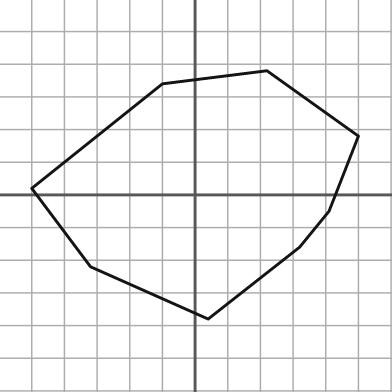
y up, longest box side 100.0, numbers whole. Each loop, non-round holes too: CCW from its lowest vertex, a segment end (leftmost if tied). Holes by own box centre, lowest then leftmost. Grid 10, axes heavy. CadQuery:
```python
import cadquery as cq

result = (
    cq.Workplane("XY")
    .moveTo(4.0, -38.0)
    .lineTo(32.0, -16.0)
    .lineTo(41.0, -5.0)
    .lineTo(50.0, 18.0)
    .lineTo(22.0, 38.0)
    .lineTo(-10.0, 34.0)
    .lineTo(-50.0, 2.0)
    .lineTo(-32.0, -22.0)
    .close()
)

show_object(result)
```